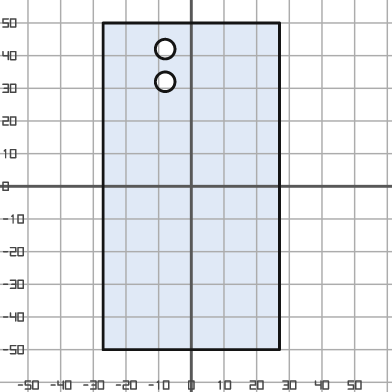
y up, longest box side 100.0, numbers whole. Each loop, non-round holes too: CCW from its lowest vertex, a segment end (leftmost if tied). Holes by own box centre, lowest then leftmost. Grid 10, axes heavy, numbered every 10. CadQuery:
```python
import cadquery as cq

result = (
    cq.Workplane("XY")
    .moveTo(-27.0, -50.0)
    .lineTo(27.0, -50.0)
    .lineTo(27.0, 50.0)
    .lineTo(-27.0, 50.0)
    .close()
    .moveTo(-8.0, 32.0)
    .circle(3.0)
    .moveTo(-8.0, 42.0)
    .circle(3.0)
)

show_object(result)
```